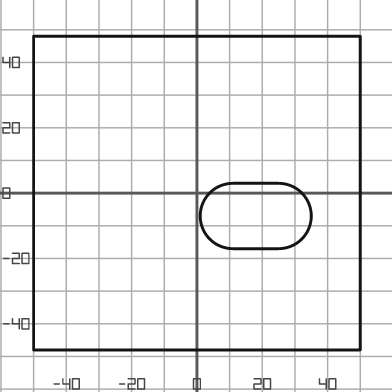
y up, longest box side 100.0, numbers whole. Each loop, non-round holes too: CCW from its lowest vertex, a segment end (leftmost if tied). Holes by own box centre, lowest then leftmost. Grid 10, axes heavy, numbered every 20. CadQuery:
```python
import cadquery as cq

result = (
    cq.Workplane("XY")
    .moveTo(-50.0, -48.0)
    .lineTo(50.0, -48.0)
    .lineTo(50.0, 48.0)
    .lineTo(-50.0, 48.0)
    .close()
    .moveTo(11.0, -17.0)
    .lineTo(25.0, -17.0)
    .threePointArc((35.0, -7.0), (25.0, 3.0))
    .lineTo(11.0, 3.0)
    .threePointArc((1.0, -7.0), (11.0, -17.0))
    .close()
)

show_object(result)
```